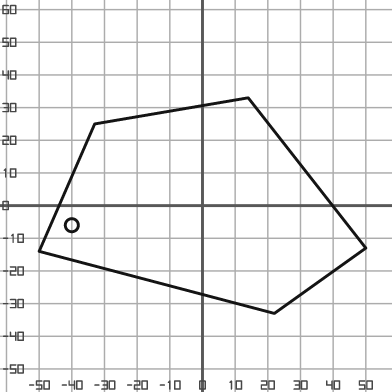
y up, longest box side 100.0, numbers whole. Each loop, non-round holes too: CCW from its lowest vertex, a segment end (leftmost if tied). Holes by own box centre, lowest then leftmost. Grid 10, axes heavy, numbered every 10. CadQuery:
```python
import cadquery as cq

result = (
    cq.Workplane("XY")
    .moveTo(22.0, -33.0)
    .lineTo(50.0, -13.0)
    .lineTo(14.0, 33.0)
    .lineTo(-33.0, 25.0)
    .lineTo(-50.0, -14.0)
    .close()
    .moveTo(-40.0, -6.0)
    .circle(2.0)
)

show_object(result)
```